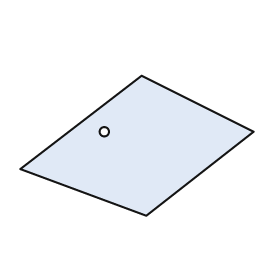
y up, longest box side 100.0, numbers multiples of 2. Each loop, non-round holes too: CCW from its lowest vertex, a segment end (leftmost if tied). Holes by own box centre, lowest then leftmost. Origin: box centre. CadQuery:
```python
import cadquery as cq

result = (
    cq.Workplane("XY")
    .moveTo(4.0, -30.0)
    .lineTo(50.0, 6.0)
    .lineTo(2.0, 30.0)
    .lineTo(-50.0, -10.0)
    .close()
    .moveTo(-14.0, 6.0)
    .circle(2.0)
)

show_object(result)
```